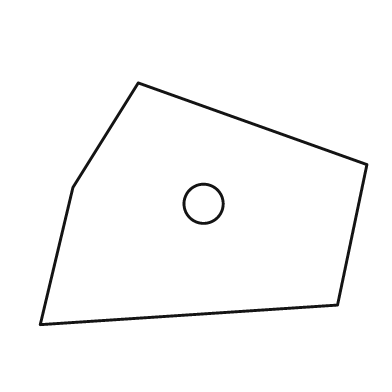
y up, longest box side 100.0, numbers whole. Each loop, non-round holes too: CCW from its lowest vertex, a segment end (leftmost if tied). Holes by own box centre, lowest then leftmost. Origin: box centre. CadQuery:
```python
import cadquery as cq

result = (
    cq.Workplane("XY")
    .moveTo(-50.0, -37.0)
    .lineTo(41.0, -31.0)
    .lineTo(50.0, 12.0)
    .lineTo(-20.0, 37.0)
    .lineTo(-40.0, 5.0)
    .close()
    .moveTo(0.0, 0.0)
    .circle(6.0)
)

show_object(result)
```